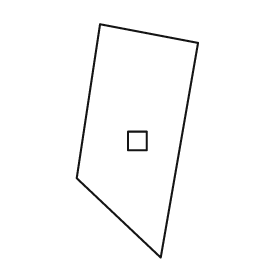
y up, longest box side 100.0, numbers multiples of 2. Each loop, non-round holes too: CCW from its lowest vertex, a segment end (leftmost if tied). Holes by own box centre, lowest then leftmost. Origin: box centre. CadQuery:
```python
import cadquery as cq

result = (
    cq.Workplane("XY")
    .moveTo(10.0, -50.0)
    .lineTo(26.0, 42.0)
    .lineTo(-16.0, 50.0)
    .lineTo(-26.0, -16.0)
    .close()
    .moveTo(-4.0, -4.0)
    .lineTo(4.0, -4.0)
    .lineTo(4.0, 4.0)
    .lineTo(-4.0, 4.0)
    .close()
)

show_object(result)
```